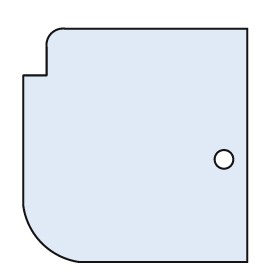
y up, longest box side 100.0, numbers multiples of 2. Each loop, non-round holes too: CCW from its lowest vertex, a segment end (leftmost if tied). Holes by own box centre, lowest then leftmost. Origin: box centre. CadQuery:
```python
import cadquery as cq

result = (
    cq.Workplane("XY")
    .moveTo(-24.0, -50.0)
    .lineTo(48.0, -50.0)
    .lineTo(48.0, 50.0)
    .lineTo(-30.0, 50.0)
    .threePointArc((-36.0, 48.0), (-38.0, 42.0))
    .lineTo(-38.0, 30.0)
    .lineTo(-48.0, 30.0)
    .lineTo(-48.0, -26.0)
    .threePointArc((-40.0, -42.0), (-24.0, -50.0))
    .close()
    .moveTo(38.0, -6.0)
    .circle(4.0)
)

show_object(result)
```